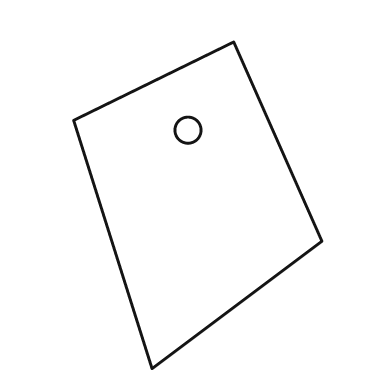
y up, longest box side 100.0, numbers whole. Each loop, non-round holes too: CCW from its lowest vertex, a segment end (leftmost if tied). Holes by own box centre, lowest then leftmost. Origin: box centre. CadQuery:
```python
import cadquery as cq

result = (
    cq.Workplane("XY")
    .moveTo(-14.0, -50.0)
    .lineTo(38.0, -11.0)
    .lineTo(11.0, 50.0)
    .lineTo(-38.0, 26.0)
    .close()
    .moveTo(-3.0, 23.0)
    .circle(4.0)
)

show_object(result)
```